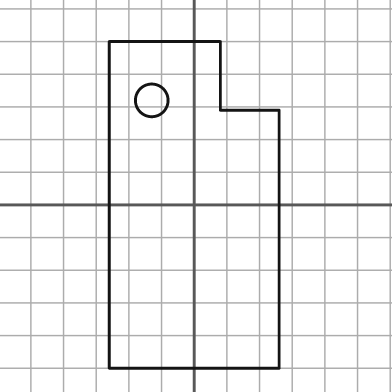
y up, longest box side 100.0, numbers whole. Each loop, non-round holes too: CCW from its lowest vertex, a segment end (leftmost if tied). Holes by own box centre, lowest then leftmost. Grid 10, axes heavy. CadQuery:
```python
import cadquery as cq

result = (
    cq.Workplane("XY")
    .moveTo(-26.0, -50.0)
    .lineTo(26.0, -50.0)
    .lineTo(26.0, 29.0)
    .lineTo(8.0, 29.0)
    .lineTo(8.0, 50.0)
    .lineTo(-26.0, 50.0)
    .close()
    .moveTo(-13.0, 32.0)
    .circle(5.0)
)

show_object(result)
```